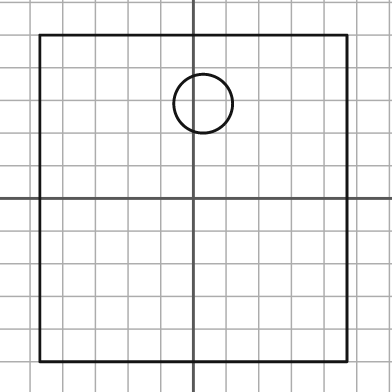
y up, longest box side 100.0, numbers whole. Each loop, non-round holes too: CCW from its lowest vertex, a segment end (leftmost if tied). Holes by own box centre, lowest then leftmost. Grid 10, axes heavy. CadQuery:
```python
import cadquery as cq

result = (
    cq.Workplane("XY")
    .moveTo(-47.0, -50.0)
    .lineTo(47.0, -50.0)
    .lineTo(47.0, 50.0)
    .lineTo(-47.0, 50.0)
    .close()
    .moveTo(3.0, 29.0)
    .circle(9.0)
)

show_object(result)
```